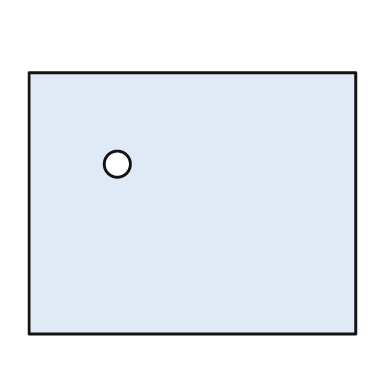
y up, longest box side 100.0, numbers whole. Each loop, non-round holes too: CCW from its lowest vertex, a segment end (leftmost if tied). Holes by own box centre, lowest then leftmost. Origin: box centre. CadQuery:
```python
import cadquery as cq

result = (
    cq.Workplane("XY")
    .moveTo(-50.0, -40.0)
    .lineTo(50.0, -40.0)
    .lineTo(50.0, 40.0)
    .lineTo(-50.0, 40.0)
    .close()
    .moveTo(-23.0, 12.0)
    .circle(4.0)
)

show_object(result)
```